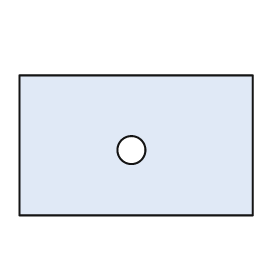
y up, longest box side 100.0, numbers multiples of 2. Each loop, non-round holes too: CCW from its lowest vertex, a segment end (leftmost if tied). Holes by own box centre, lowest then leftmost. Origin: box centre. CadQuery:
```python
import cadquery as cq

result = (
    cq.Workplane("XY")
    .moveTo(-50.0, -30.0)
    .lineTo(50.0, -30.0)
    .lineTo(50.0, 30.0)
    .lineTo(-50.0, 30.0)
    .close()
    .moveTo(-2.0, -2.0)
    .circle(6.0)
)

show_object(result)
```